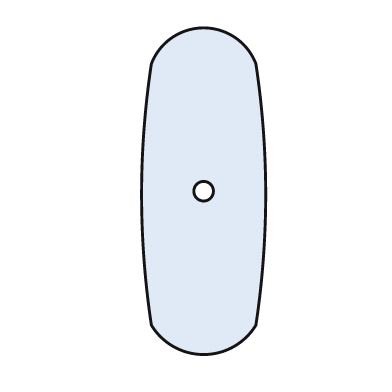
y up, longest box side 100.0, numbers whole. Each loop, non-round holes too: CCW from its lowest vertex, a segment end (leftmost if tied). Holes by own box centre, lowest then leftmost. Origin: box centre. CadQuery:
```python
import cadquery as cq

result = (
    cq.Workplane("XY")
    .moveTo(-16.0, -41.0)
    .threePointArc((0.0, -50.0), (16.0, -41.0))
    .threePointArc((19.0, -1.0), (16.0, 39.0))
    .threePointArc((0.0, 50.0), (-16.0, 39.0))
    .threePointArc((-19.0, -1.0), (-16.0, -41.0))
    .close()
    .moveTo(0.0, 0.0)
    .circle(3.0)
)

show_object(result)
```